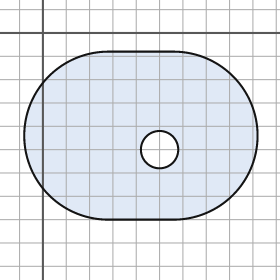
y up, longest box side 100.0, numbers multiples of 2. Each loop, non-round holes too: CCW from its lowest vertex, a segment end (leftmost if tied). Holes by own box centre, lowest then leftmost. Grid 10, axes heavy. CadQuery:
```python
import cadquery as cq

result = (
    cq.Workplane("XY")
    .moveTo(28.0, -80.0)
    .lineTo(56.0, -80.0)
    .threePointArc((92.0, -44.0), (56.0, -8.0))
    .lineTo(28.0, -8.0)
    .threePointArc((-8.0, -44.0), (28.0, -80.0))
    .close()
    .moveTo(50.0, -50.0)
    .circle(8.0)
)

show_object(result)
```